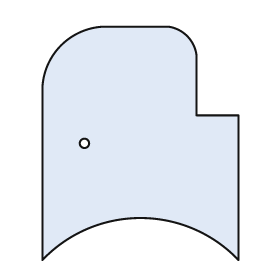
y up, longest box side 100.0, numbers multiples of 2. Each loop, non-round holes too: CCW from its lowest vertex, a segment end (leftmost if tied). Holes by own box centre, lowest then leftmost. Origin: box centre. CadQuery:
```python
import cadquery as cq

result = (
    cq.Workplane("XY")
    .moveTo(-42.0, -50.0)
    .threePointArc((0.0, -32.0), (42.0, -50.0))
    .lineTo(42.0, 12.0)
    .lineTo(24.0, 12.0)
    .lineTo(24.0, 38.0)
    .threePointArc((20.0, 46.0), (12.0, 50.0))
    .lineTo(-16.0, 50.0)
    .threePointArc((-34.0, 42.0), (-42.0, 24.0))
    .close()
    .moveTo(-24.0, 0.0)
    .circle(2.0)
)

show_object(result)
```